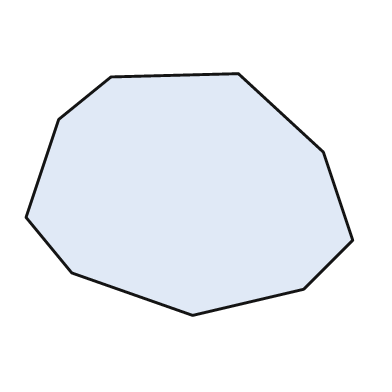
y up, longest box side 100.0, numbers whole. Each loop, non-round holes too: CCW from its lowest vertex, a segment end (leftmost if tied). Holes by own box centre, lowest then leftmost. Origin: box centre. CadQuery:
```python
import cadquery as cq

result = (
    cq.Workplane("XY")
    .moveTo(1.0, -37.0)
    .lineTo(35.0, -29.0)
    .lineTo(50.0, -14.0)
    .lineTo(41.0, 13.0)
    .lineTo(15.0, 37.0)
    .lineTo(-24.0, 36.0)
    .lineTo(-40.0, 23.0)
    .lineTo(-50.0, -7.0)
    .lineTo(-36.0, -24.0)
    .close()
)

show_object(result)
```